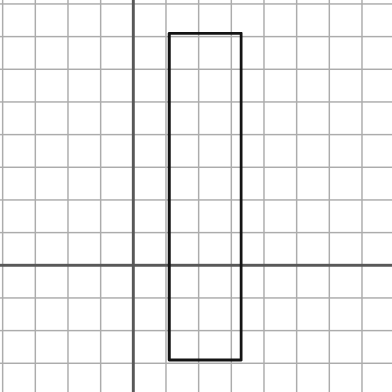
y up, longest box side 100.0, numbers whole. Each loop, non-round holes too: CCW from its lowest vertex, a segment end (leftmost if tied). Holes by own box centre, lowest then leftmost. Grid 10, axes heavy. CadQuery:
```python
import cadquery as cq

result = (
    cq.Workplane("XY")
    .moveTo(11.0, -29.0)
    .lineTo(33.0, -29.0)
    .lineTo(33.0, 71.0)
    .lineTo(11.0, 71.0)
    .close()
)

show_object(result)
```